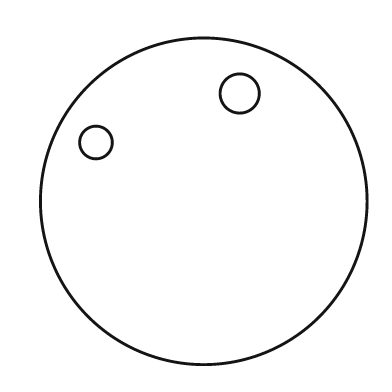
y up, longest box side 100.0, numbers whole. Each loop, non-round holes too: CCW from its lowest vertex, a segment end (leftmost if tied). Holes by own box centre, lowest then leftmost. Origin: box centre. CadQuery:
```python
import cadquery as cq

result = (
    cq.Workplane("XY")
    .moveTo(0.0, 0.0)
    .circle(50.0)
    .moveTo(-33.0, 18.0)
    .circle(5.0)
    .moveTo(11.0, 33.0)
    .circle(6.0)
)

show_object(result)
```